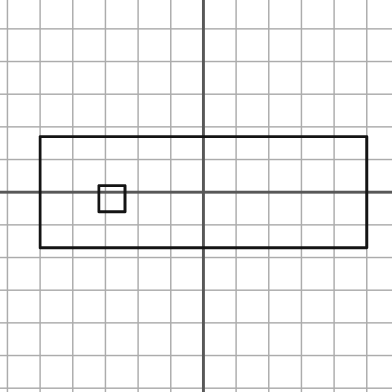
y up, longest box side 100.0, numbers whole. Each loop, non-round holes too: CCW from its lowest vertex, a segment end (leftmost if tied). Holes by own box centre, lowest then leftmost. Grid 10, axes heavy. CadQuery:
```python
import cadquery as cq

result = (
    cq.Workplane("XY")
    .moveTo(-50.0, -17.0)
    .lineTo(50.0, -17.0)
    .lineTo(50.0, 17.0)
    .lineTo(-50.0, 17.0)
    .close()
    .moveTo(-32.0, -6.0)
    .lineTo(-24.0, -6.0)
    .lineTo(-24.0, 2.0)
    .lineTo(-32.0, 2.0)
    .close()
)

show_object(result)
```